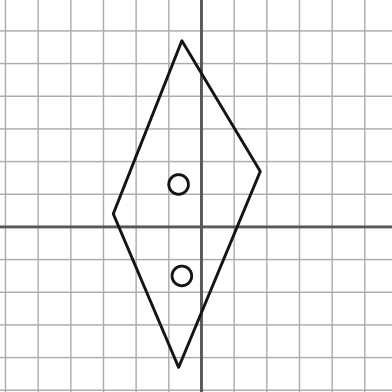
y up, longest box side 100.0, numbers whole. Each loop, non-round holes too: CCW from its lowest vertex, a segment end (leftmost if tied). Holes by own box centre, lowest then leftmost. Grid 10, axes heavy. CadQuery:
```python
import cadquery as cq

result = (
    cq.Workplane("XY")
    .moveTo(-7.0, -43.0)
    .lineTo(18.0, 17.0)
    .lineTo(-6.0, 57.0)
    .lineTo(-27.0, 4.0)
    .close()
    .moveTo(-6.0, -15.0)
    .circle(3.0)
    .moveTo(-7.0, 13.0)
    .circle(3.0)
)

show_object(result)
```